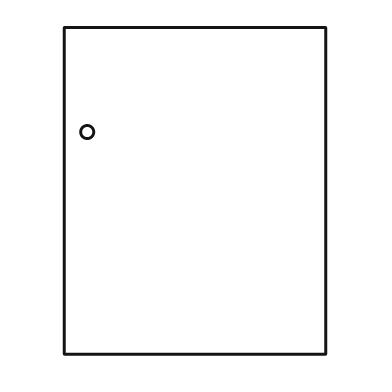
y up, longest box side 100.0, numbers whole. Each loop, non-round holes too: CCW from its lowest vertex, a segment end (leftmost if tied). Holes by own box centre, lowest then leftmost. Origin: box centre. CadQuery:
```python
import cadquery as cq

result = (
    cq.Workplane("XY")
    .moveTo(-40.0, -50.0)
    .lineTo(40.0, -50.0)
    .lineTo(40.0, 50.0)
    .lineTo(-40.0, 50.0)
    .close()
    .moveTo(-33.0, 18.0)
    .circle(2.0)
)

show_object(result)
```